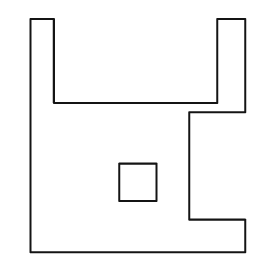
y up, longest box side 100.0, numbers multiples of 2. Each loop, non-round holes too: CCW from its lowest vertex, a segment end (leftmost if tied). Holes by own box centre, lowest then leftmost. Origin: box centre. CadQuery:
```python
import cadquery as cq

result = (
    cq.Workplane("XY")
    .moveTo(-46.0, -50.0)
    .lineTo(46.0, -50.0)
    .lineTo(46.0, -36.0)
    .lineTo(22.0, -36.0)
    .lineTo(22.0, 10.0)
    .lineTo(46.0, 10.0)
    .lineTo(46.0, 50.0)
    .lineTo(34.0, 50.0)
    .lineTo(34.0, 14.0)
    .lineTo(-36.0, 14.0)
    .lineTo(-36.0, 50.0)
    .lineTo(-46.0, 50.0)
    .close()
    .moveTo(-8.0, -28.0)
    .lineTo(8.0, -28.0)
    .lineTo(8.0, -12.0)
    .lineTo(-8.0, -12.0)
    .close()
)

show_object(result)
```